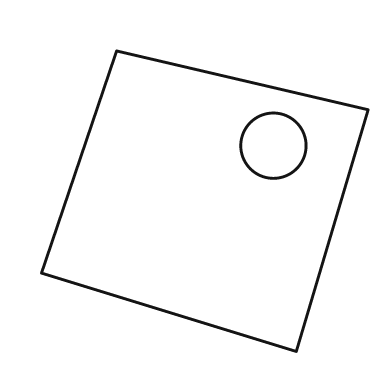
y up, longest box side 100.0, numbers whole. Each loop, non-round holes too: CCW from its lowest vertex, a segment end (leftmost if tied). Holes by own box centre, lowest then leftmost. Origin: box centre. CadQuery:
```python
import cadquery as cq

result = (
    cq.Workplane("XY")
    .moveTo(28.0, -46.0)
    .lineTo(50.0, 28.0)
    .lineTo(-27.0, 46.0)
    .lineTo(-50.0, -22.0)
    .close()
    .moveTo(21.0, 17.0)
    .circle(10.0)
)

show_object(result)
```